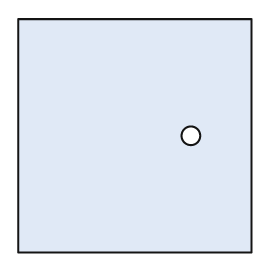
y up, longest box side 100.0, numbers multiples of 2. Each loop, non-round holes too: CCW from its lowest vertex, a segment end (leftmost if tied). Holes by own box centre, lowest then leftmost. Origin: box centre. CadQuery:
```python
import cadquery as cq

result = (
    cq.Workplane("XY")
    .moveTo(-50.0, -50.0)
    .lineTo(50.0, -50.0)
    .lineTo(50.0, 50.0)
    .lineTo(-50.0, 50.0)
    .close()
    .moveTo(24.0, 0.0)
    .circle(4.0)
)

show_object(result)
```